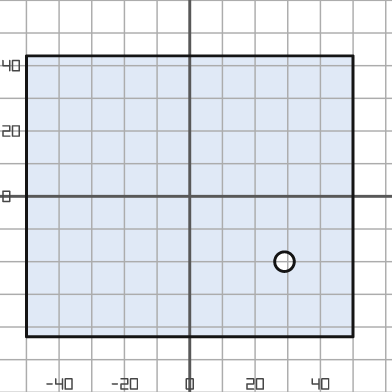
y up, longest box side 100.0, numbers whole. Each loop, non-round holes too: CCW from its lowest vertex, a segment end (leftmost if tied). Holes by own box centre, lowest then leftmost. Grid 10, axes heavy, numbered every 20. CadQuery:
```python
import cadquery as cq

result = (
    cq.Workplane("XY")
    .moveTo(-50.0, -43.0)
    .lineTo(50.0, -43.0)
    .lineTo(50.0, 43.0)
    .lineTo(-50.0, 43.0)
    .close()
    .moveTo(29.0, -20.0)
    .circle(3.0)
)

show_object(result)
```